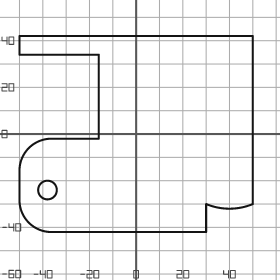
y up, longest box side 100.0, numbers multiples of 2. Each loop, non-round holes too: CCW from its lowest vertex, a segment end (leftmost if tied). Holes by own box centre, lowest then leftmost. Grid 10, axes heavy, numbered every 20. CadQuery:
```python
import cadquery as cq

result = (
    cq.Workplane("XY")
    .moveTo(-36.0, -42.0)
    .lineTo(30.0, -42.0)
    .lineTo(30.0, -30.0)
    .threePointArc((40.0, -32.0), (50.0, -30.0))
    .lineTo(50.0, 42.0)
    .lineTo(-50.0, 42.0)
    .lineTo(-50.0, 34.0)
    .lineTo(-16.0, 34.0)
    .lineTo(-16.0, -2.0)
    .lineTo(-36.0, -2.0)
    .threePointArc((-46.0, -6.0), (-50.0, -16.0))
    .lineTo(-50.0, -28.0)
    .threePointArc((-46.0, -38.0), (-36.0, -42.0))
    .close()
    .moveTo(-38.0, -24.0)
    .circle(4.0)
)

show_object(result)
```